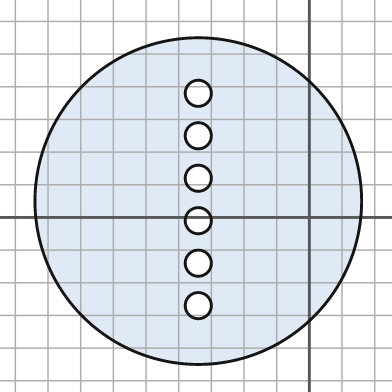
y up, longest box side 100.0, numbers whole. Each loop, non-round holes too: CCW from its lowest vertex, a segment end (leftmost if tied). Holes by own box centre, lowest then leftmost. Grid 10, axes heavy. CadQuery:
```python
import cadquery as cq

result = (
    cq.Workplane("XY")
    .moveTo(-34.0, 5.0)
    .circle(50.0)
    .moveTo(-34.0, -27.0)
    .circle(4.0)
    .moveTo(-34.0, -14.0)
    .circle(4.0)
    .moveTo(-34.0, -1.0)
    .circle(4.0)
    .moveTo(-34.0, 12.0)
    .circle(4.0)
    .moveTo(-34.0, 25.0)
    .circle(4.0)
    .moveTo(-34.0, 38.0)
    .circle(4.0)
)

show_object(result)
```